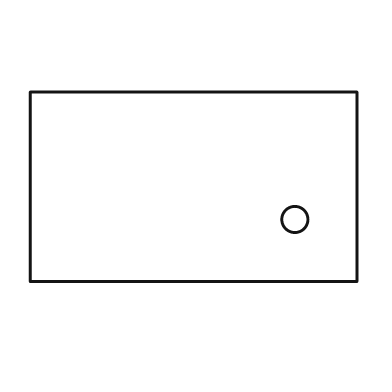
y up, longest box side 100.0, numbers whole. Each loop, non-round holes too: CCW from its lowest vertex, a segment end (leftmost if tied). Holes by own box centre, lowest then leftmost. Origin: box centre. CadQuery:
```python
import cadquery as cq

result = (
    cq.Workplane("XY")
    .moveTo(-50.0, -29.0)
    .lineTo(50.0, -29.0)
    .lineTo(50.0, 29.0)
    .lineTo(-50.0, 29.0)
    .close()
    .moveTo(31.0, -10.0)
    .circle(4.0)
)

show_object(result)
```